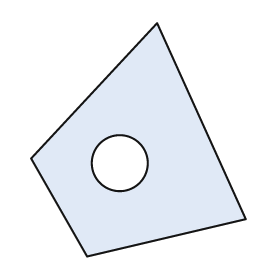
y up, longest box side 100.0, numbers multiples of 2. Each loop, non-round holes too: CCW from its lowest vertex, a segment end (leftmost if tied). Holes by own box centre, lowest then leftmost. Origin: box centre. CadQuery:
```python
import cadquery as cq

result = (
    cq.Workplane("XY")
    .moveTo(-22.0, -50.0)
    .lineTo(46.0, -34.0)
    .lineTo(8.0, 50.0)
    .lineTo(-46.0, -8.0)
    .close()
    .moveTo(-8.0, -10.0)
    .circle(12.0)
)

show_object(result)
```